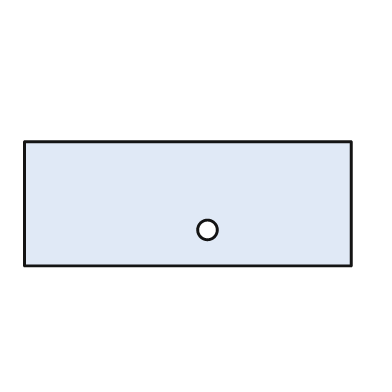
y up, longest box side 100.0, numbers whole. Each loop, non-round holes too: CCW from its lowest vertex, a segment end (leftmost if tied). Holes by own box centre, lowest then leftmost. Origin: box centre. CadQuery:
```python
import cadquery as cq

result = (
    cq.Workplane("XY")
    .moveTo(-50.0, -19.0)
    .lineTo(50.0, -19.0)
    .lineTo(50.0, 19.0)
    .lineTo(-50.0, 19.0)
    .close()
    .moveTo(6.0, -8.0)
    .circle(3.0)
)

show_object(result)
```